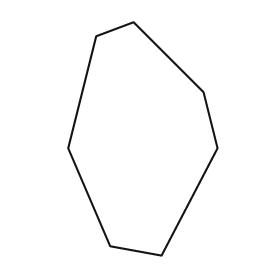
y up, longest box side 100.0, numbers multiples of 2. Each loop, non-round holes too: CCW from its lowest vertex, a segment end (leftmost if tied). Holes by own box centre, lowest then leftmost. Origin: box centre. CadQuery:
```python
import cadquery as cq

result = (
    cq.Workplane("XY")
    .moveTo(8.0, -50.0)
    .lineTo(32.0, -4.0)
    .lineTo(26.0, 20.0)
    .lineTo(-4.0, 50.0)
    .lineTo(-20.0, 44.0)
    .lineTo(-32.0, -4.0)
    .lineTo(-14.0, -46.0)
    .close()
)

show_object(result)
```